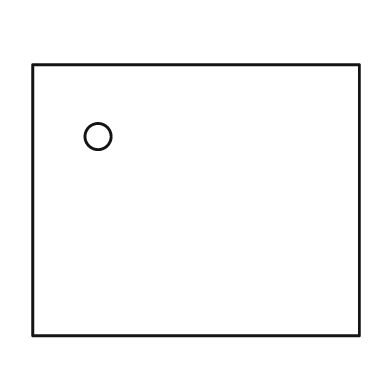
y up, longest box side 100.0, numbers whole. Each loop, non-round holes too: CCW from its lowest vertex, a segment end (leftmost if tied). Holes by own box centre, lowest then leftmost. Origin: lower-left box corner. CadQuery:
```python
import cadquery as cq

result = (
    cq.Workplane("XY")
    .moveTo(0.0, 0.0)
    .lineTo(100.0, 0.0)
    .lineTo(100.0, 83.0)
    .lineTo(0.0, 83.0)
    .close()
    .moveTo(20.0, 61.0)
    .circle(4.0)
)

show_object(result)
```